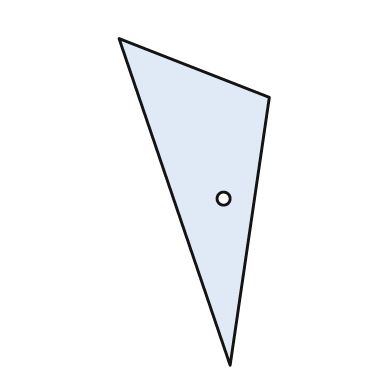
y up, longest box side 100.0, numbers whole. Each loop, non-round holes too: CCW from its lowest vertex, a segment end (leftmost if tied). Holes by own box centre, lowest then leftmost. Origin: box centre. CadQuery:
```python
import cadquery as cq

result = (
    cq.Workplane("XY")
    .moveTo(11.0, -50.0)
    .lineTo(23.0, 32.0)
    .lineTo(-23.0, 50.0)
    .close()
    .moveTo(9.0, 1.0)
    .circle(2.0)
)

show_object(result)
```